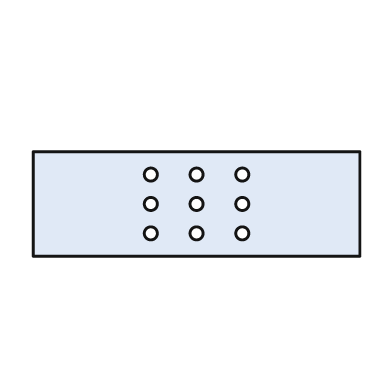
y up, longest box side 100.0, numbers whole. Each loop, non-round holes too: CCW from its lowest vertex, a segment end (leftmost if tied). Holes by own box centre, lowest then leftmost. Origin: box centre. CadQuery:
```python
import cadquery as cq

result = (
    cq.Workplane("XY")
    .moveTo(-50.0, -16.0)
    .lineTo(50.0, -16.0)
    .lineTo(50.0, 16.0)
    .lineTo(-50.0, 16.0)
    .close()
    .moveTo(-14.0, -9.0)
    .circle(2.0)
    .moveTo(0.0, -9.0)
    .circle(2.0)
    .moveTo(14.0, -9.0)
    .circle(2.0)
    .moveTo(-14.0, 0.0)
    .circle(2.0)
    .moveTo(0.0, 0.0)
    .circle(2.0)
    .moveTo(14.0, 0.0)
    .circle(2.0)
    .moveTo(-14.0, 9.0)
    .circle(2.0)
    .moveTo(0.0, 9.0)
    .circle(2.0)
    .moveTo(14.0, 9.0)
    .circle(2.0)
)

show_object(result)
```